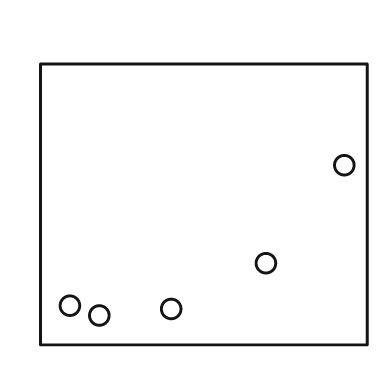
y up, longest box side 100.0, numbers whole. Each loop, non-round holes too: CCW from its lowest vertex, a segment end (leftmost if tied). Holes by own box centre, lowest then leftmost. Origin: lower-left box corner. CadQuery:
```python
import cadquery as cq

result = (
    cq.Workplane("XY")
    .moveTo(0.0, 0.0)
    .lineTo(100.0, 0.0)
    .lineTo(100.0, 86.0)
    .lineTo(0.0, 86.0)
    .close()
    .moveTo(18.0, 9.0)
    .circle(3.0)
    .moveTo(40.0, 11.0)
    .circle(3.0)
    .moveTo(9.0, 12.0)
    .circle(3.0)
    .moveTo(69.0, 25.0)
    .circle(3.0)
    .moveTo(93.0, 55.0)
    .circle(3.0)
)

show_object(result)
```